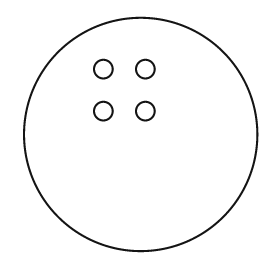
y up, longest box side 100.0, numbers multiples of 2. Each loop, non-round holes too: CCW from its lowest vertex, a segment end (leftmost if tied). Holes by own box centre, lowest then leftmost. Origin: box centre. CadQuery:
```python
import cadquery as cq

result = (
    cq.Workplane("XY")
    .moveTo(0.0, 0.0)
    .circle(50.0)
    .moveTo(-16.0, 10.0)
    .circle(4.0)
    .moveTo(2.0, 10.0)
    .circle(4.0)
    .moveTo(-16.0, 28.0)
    .circle(4.0)
    .moveTo(2.0, 28.0)
    .circle(4.0)
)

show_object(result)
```